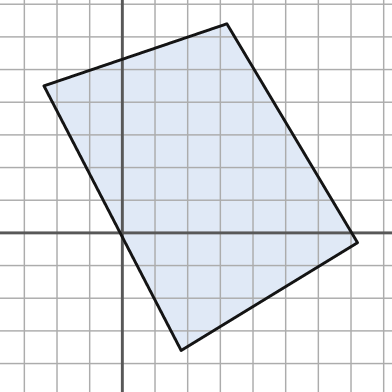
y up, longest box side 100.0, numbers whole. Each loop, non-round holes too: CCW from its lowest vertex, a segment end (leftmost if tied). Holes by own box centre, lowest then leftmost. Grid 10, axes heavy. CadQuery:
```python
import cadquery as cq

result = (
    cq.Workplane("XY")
    .moveTo(18.0, -36.0)
    .lineTo(72.0, -3.0)
    .lineTo(32.0, 64.0)
    .lineTo(-24.0, 45.0)
    .close()
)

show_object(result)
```